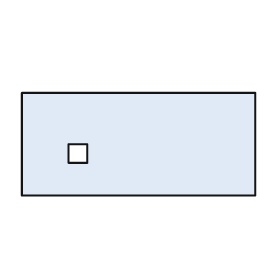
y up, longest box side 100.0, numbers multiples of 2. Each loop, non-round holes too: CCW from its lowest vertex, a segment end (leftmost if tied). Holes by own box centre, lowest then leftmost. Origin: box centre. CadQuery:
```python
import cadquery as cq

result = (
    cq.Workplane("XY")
    .moveTo(-50.0, -22.0)
    .lineTo(50.0, -22.0)
    .lineTo(50.0, 22.0)
    .lineTo(-50.0, 22.0)
    .close()
    .moveTo(-30.0, -8.0)
    .lineTo(-22.0, -8.0)
    .lineTo(-22.0, 0.0)
    .lineTo(-30.0, 0.0)
    .close()
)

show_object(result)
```